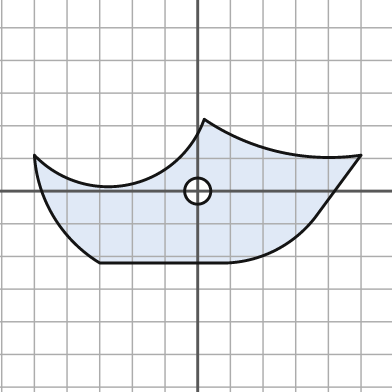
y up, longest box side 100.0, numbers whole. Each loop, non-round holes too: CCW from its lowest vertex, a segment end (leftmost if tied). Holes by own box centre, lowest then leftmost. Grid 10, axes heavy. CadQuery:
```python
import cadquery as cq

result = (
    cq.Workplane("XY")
    .moveTo(-30.0, -22.0)
    .lineTo(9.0, -22.0)
    .threePointArc((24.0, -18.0), (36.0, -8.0))
    .lineTo(50.0, 11.0)
    .threePointArc((25.0, 12.0), (2.0, 22.0))
    .threePointArc((-21.0, 2.0), (-50.0, 11.0))
    .threePointArc((-44.0, -8.0), (-30.0, -22.0))
    .close()
    .moveTo(0.0, 0.0)
    .circle(4.0)
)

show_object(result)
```